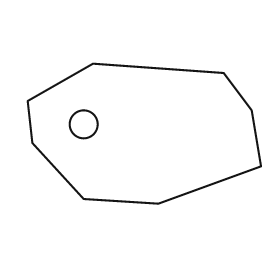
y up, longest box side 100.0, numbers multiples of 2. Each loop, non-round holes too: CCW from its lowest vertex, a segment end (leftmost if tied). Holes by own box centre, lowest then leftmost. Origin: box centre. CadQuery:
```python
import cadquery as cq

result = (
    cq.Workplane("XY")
    .moveTo(6.0, -30.0)
    .lineTo(50.0, -14.0)
    .lineTo(46.0, 10.0)
    .lineTo(34.0, 26.0)
    .lineTo(-22.0, 30.0)
    .lineTo(-50.0, 14.0)
    .lineTo(-48.0, -4.0)
    .lineTo(-26.0, -28.0)
    .close()
    .moveTo(-26.0, 4.0)
    .circle(6.0)
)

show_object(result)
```